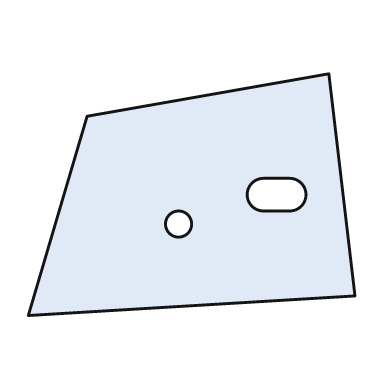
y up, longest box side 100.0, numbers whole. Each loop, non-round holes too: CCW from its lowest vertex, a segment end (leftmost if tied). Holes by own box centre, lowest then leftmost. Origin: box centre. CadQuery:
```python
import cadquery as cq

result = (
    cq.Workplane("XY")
    .moveTo(-50.0, -37.0)
    .lineTo(50.0, -31.0)
    .lineTo(42.0, 37.0)
    .lineTo(-32.0, 24.0)
    .close()
    .moveTo(-4.0, -9.0)
    .circle(4.0)
    .moveTo(22.0, -5.0)
    .lineTo(30.0, -5.0)
    .threePointArc((35.0, 0.0), (30.0, 5.0))
    .lineTo(22.0, 5.0)
    .threePointArc((17.0, 0.0), (22.0, -5.0))
    .close()
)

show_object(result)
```